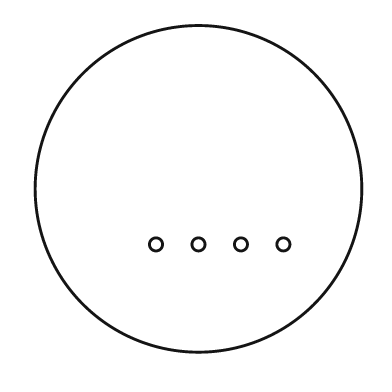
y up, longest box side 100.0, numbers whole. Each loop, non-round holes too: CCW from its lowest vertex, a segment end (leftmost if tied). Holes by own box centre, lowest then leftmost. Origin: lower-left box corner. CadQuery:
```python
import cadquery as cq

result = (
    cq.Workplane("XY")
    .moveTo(50.0, 50.0)
    .circle(50.0)
    .moveTo(37.0, 33.0)
    .circle(2.0)
    .moveTo(50.0, 33.0)
    .circle(2.0)
    .moveTo(63.0, 33.0)
    .circle(2.0)
    .moveTo(76.0, 33.0)
    .circle(2.0)
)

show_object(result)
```